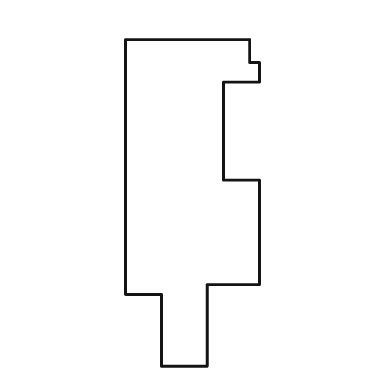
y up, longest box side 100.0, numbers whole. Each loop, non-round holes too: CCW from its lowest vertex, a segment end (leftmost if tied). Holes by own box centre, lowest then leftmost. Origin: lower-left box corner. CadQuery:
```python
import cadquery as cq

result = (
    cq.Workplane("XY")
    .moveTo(11.0, 0.0)
    .lineTo(25.0, 0.0)
    .lineTo(25.0, 25.0)
    .lineTo(41.0, 25.0)
    .lineTo(41.0, 57.0)
    .lineTo(30.0, 57.0)
    .lineTo(30.0, 87.0)
    .lineTo(41.0, 87.0)
    .lineTo(41.0, 93.0)
    .lineTo(38.0, 93.0)
    .lineTo(38.0, 100.0)
    .lineTo(0.0, 100.0)
    .lineTo(0.0, 22.0)
    .lineTo(11.0, 22.0)
    .close()
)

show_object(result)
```